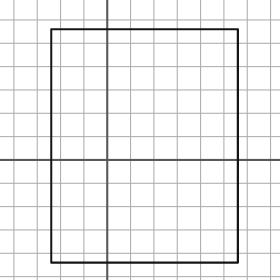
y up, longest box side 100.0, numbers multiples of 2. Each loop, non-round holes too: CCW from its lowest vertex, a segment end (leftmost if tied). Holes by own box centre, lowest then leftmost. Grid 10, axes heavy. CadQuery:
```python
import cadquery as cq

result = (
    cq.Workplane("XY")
    .moveTo(-24.0, -44.0)
    .lineTo(56.0, -44.0)
    .lineTo(56.0, 56.0)
    .lineTo(-24.0, 56.0)
    .close()
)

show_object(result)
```